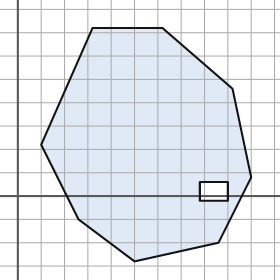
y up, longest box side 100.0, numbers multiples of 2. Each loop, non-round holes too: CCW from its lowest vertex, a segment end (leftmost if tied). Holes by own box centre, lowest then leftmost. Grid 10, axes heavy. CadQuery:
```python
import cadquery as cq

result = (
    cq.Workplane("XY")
    .moveTo(50.0, -28.0)
    .lineTo(86.0, -20.0)
    .lineTo(100.0, 8.0)
    .lineTo(92.0, 46.0)
    .lineTo(62.0, 72.0)
    .lineTo(32.0, 72.0)
    .lineTo(10.0, 22.0)
    .lineTo(26.0, -10.0)
    .close()
    .moveTo(78.0, -2.0)
    .lineTo(90.0, -2.0)
    .lineTo(90.0, 6.0)
    .lineTo(78.0, 6.0)
    .close()
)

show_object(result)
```